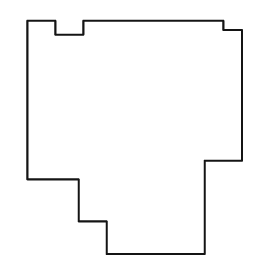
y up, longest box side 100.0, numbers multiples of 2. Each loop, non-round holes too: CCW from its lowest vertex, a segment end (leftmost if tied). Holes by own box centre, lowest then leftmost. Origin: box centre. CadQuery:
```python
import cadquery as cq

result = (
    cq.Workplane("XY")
    .moveTo(-12.0, -50.0)
    .lineTo(30.0, -50.0)
    .lineTo(30.0, -10.0)
    .lineTo(46.0, -10.0)
    .lineTo(46.0, 46.0)
    .lineTo(38.0, 46.0)
    .lineTo(38.0, 50.0)
    .lineTo(-22.0, 50.0)
    .lineTo(-22.0, 44.0)
    .lineTo(-34.0, 44.0)
    .lineTo(-34.0, 50.0)
    .lineTo(-46.0, 50.0)
    .lineTo(-46.0, -18.0)
    .lineTo(-24.0, -18.0)
    .lineTo(-24.0, -36.0)
    .lineTo(-12.0, -36.0)
    .close()
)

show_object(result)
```